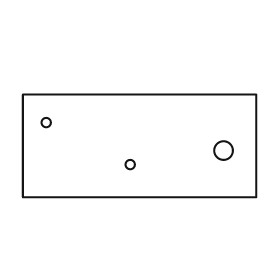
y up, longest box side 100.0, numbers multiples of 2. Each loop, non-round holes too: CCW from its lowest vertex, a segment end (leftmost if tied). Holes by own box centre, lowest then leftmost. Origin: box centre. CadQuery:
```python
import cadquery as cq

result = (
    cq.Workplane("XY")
    .moveTo(-50.0, -22.0)
    .lineTo(50.0, -22.0)
    .lineTo(50.0, 22.0)
    .lineTo(-50.0, 22.0)
    .close()
    .moveTo(-4.0, -8.0)
    .circle(2.0)
    .moveTo(36.0, -2.0)
    .circle(4.0)
    .moveTo(-40.0, 10.0)
    .circle(2.0)
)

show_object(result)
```